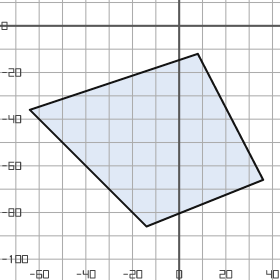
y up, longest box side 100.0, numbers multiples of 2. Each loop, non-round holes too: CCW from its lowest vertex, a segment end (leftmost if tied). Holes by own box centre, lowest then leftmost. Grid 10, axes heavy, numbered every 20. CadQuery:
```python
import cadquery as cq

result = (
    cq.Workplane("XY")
    .moveTo(-14.0, -86.0)
    .lineTo(36.0, -66.0)
    .lineTo(8.0, -12.0)
    .lineTo(-64.0, -36.0)
    .close()
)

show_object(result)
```